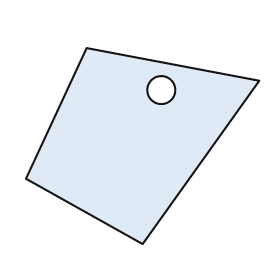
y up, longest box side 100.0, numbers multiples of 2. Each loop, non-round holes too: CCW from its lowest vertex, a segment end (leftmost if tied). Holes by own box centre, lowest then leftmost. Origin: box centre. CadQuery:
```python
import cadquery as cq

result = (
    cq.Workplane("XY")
    .moveTo(0.0, -42.0)
    .lineTo(50.0, 28.0)
    .lineTo(-24.0, 42.0)
    .lineTo(-50.0, -14.0)
    .close()
    .moveTo(8.0, 24.0)
    .circle(6.0)
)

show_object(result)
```